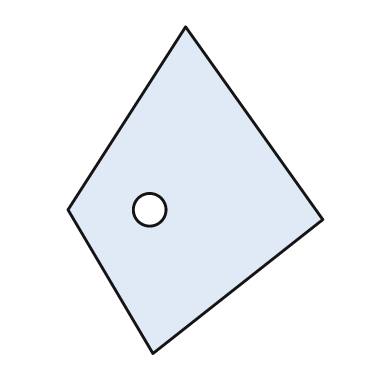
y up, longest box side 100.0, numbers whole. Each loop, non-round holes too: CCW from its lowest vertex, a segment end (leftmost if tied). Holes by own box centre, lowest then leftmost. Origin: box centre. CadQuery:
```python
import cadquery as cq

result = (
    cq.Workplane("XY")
    .moveTo(-13.0, -50.0)
    .lineTo(39.0, -9.0)
    .lineTo(-3.0, 50.0)
    .lineTo(-39.0, -6.0)
    .close()
    .moveTo(-14.0, -6.0)
    .circle(5.0)
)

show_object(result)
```